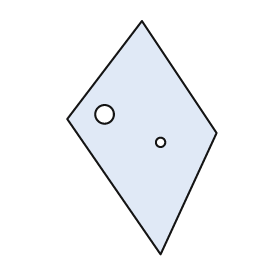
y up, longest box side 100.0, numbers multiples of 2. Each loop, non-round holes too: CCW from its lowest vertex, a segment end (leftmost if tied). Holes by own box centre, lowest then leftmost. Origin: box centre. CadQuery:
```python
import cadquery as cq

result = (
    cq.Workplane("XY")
    .moveTo(8.0, -50.0)
    .lineTo(32.0, 2.0)
    .lineTo(0.0, 50.0)
    .lineTo(-32.0, 8.0)
    .close()
    .moveTo(8.0, -2.0)
    .circle(2.0)
    .moveTo(-16.0, 10.0)
    .circle(4.0)
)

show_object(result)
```